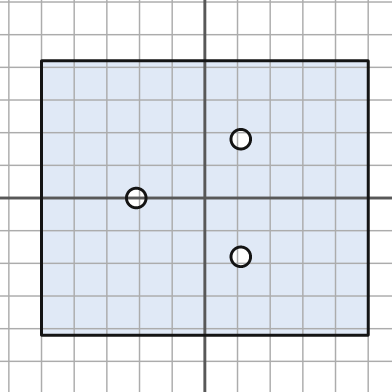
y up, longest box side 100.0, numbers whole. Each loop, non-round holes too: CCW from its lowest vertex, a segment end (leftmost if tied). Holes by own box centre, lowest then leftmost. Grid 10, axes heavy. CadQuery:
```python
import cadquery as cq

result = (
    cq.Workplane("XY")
    .moveTo(-50.0, -42.0)
    .lineTo(50.0, -42.0)
    .lineTo(50.0, 42.0)
    .lineTo(-50.0, 42.0)
    .close()
    .moveTo(11.0, -18.0)
    .circle(3.0)
    .moveTo(-21.0, 0.0)
    .circle(3.0)
    .moveTo(11.0, 18.0)
    .circle(3.0)
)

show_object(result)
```